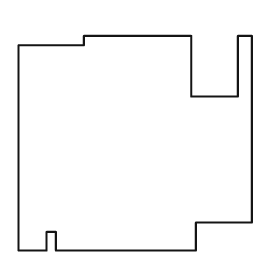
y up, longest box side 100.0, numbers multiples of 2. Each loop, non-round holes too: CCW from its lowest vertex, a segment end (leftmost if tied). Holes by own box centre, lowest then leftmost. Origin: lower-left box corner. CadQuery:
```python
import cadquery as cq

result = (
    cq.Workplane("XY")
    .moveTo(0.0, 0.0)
    .lineTo(12.0, 0.0)
    .lineTo(12.0, 8.0)
    .lineTo(16.0, 8.0)
    .lineTo(16.0, 0.0)
    .lineTo(76.0, 0.0)
    .lineTo(76.0, 12.0)
    .lineTo(100.0, 12.0)
    .lineTo(100.0, 92.0)
    .lineTo(94.0, 92.0)
    .lineTo(94.0, 66.0)
    .lineTo(74.0, 66.0)
    .lineTo(74.0, 92.0)
    .lineTo(28.0, 92.0)
    .lineTo(28.0, 88.0)
    .lineTo(0.0, 88.0)
    .close()
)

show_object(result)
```